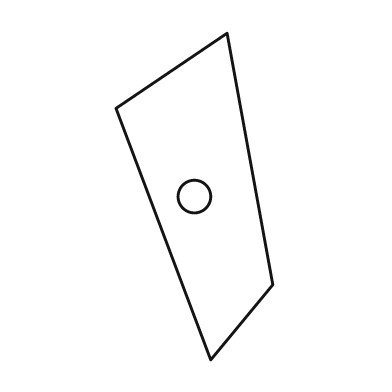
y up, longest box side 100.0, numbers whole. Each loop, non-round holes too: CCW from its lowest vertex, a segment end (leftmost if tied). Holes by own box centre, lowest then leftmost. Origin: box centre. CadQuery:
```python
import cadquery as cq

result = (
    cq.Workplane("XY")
    .moveTo(5.0, -50.0)
    .lineTo(24.0, -27.0)
    .lineTo(10.0, 50.0)
    .lineTo(-24.0, 27.0)
    .close()
    .moveTo(0.0, 0.0)
    .circle(5.0)
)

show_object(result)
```